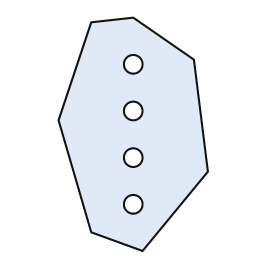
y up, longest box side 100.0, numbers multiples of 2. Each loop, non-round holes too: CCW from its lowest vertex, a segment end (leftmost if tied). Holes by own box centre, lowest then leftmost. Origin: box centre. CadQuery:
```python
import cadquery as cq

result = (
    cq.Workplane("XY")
    .moveTo(4.0, -50.0)
    .lineTo(32.0, -16.0)
    .lineTo(26.0, 32.0)
    .lineTo(0.0, 50.0)
    .lineTo(-18.0, 48.0)
    .lineTo(-32.0, 6.0)
    .lineTo(-18.0, -42.0)
    .close()
    .moveTo(0.0, -30.0)
    .circle(4.0)
    .moveTo(0.0, -10.0)
    .circle(4.0)
    .moveTo(0.0, 10.0)
    .circle(4.0)
    .moveTo(0.0, 30.0)
    .circle(4.0)
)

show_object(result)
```